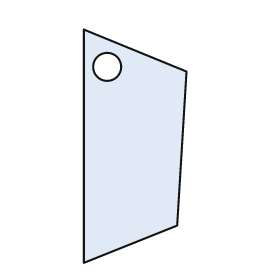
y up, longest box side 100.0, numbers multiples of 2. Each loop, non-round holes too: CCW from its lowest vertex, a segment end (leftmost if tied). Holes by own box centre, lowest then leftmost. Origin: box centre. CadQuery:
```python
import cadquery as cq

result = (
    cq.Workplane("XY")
    .moveTo(-22.0, -50.0)
    .lineTo(18.0, -34.0)
    .lineTo(22.0, 32.0)
    .lineTo(-22.0, 50.0)
    .close()
    .moveTo(-12.0, 34.0)
    .circle(6.0)
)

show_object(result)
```